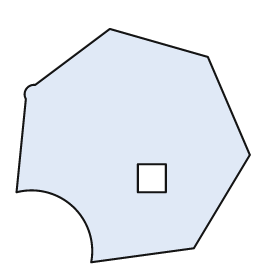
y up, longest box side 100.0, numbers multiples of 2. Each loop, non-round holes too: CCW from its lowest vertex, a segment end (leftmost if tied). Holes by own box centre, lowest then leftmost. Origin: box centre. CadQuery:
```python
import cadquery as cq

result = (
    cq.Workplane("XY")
    .moveTo(-18.0, -50.0)
    .lineTo(26.0, -44.0)
    .lineTo(50.0, -4.0)
    .lineTo(32.0, 38.0)
    .lineTo(-10.0, 50.0)
    .lineTo(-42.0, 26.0)
    .threePointArc((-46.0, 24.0), (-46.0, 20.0))
    .lineTo(-50.0, -20.0)
    .threePointArc((-26.0, -26.0), (-18.0, -50.0))
    .close()
    .moveTo(2.0, -20.0)
    .lineTo(14.0, -20.0)
    .lineTo(14.0, -8.0)
    .lineTo(2.0, -8.0)
    .close()
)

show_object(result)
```